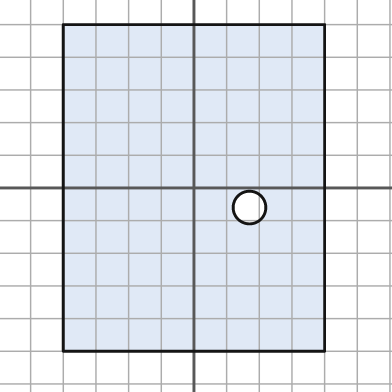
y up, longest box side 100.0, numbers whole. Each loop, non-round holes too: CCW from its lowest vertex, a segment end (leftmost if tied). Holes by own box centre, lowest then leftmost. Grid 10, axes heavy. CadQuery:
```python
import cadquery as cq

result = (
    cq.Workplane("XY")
    .moveTo(-40.0, -50.0)
    .lineTo(40.0, -50.0)
    .lineTo(40.0, 50.0)
    .lineTo(-40.0, 50.0)
    .close()
    .moveTo(17.0, -6.0)
    .circle(5.0)
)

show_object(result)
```